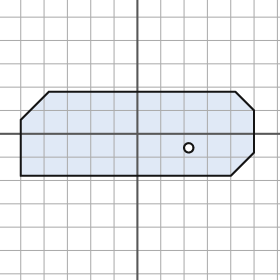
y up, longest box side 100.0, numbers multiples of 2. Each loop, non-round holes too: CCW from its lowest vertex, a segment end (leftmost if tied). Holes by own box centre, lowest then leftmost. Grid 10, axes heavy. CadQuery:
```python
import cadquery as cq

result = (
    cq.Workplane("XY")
    .moveTo(-50.0, -18.0)
    .lineTo(40.0, -18.0)
    .lineTo(50.0, -8.0)
    .lineTo(50.0, 10.0)
    .lineTo(42.0, 18.0)
    .lineTo(-38.0, 18.0)
    .lineTo(-50.0, 6.0)
    .close()
    .moveTo(22.0, -6.0)
    .circle(2.0)
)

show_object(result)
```